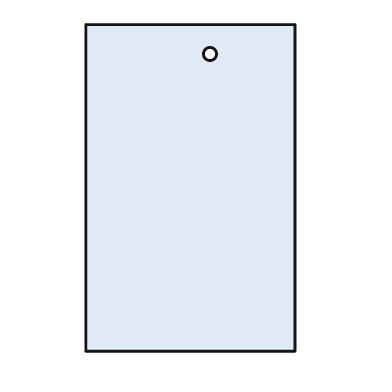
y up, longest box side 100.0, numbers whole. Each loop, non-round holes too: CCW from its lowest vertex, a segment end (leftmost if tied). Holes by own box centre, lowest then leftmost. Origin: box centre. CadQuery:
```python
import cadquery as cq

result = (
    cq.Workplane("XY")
    .moveTo(-32.0, -50.0)
    .lineTo(32.0, -50.0)
    .lineTo(32.0, 50.0)
    .lineTo(-32.0, 50.0)
    .close()
    .moveTo(6.0, 41.0)
    .circle(2.0)
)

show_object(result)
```